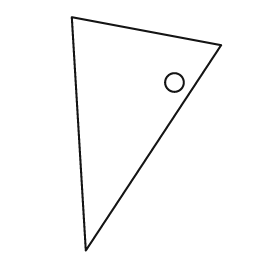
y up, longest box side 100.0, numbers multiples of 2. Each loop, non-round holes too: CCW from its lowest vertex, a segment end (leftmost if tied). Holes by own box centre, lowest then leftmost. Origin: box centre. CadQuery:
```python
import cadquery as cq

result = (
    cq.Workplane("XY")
    .moveTo(-26.0, -50.0)
    .lineTo(32.0, 38.0)
    .lineTo(-32.0, 50.0)
    .close()
    .moveTo(12.0, 22.0)
    .circle(4.0)
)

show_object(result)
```